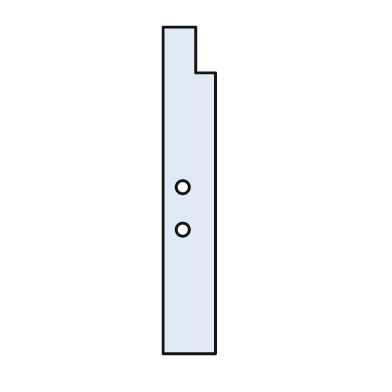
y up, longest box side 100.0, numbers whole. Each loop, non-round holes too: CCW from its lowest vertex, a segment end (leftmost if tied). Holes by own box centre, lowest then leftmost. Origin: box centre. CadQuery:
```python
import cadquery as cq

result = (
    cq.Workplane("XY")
    .moveTo(-8.0, -50.0)
    .lineTo(8.0, -50.0)
    .lineTo(8.0, 36.0)
    .lineTo(2.0, 36.0)
    .lineTo(2.0, 50.0)
    .lineTo(-8.0, 50.0)
    .close()
    .moveTo(-2.0, -12.0)
    .circle(2.0)
    .moveTo(-2.0, 1.0)
    .circle(2.0)
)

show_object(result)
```